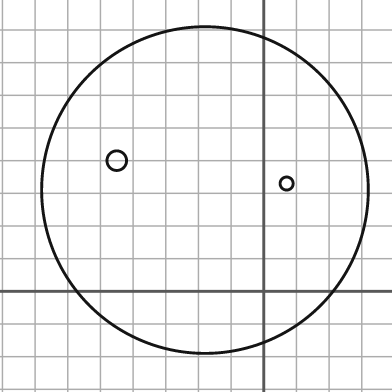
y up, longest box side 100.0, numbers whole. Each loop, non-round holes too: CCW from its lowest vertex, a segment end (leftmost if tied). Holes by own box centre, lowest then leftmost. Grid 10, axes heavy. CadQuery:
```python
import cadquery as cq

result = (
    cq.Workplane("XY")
    .moveTo(-18.0, 31.0)
    .circle(50.0)
    .moveTo(7.0, 33.0)
    .circle(2.0)
    .moveTo(-45.0, 40.0)
    .circle(3.0)
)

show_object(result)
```